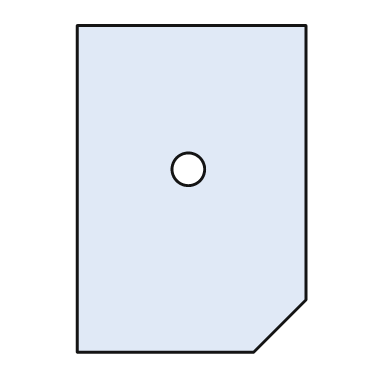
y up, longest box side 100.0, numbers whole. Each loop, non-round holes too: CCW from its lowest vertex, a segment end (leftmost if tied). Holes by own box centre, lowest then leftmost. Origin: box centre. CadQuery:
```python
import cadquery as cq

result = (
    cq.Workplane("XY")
    .moveTo(-35.0, -50.0)
    .lineTo(19.0, -50.0)
    .lineTo(35.0, -34.0)
    .lineTo(35.0, 50.0)
    .lineTo(-35.0, 50.0)
    .close()
    .moveTo(-1.0, 6.0)
    .circle(5.0)
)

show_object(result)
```